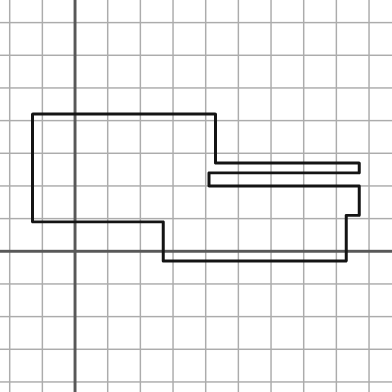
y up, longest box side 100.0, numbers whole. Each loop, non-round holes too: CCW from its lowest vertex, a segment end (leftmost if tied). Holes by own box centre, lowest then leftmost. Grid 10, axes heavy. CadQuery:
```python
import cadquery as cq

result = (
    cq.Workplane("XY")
    .moveTo(27.0, -3.0)
    .lineTo(83.0, -3.0)
    .lineTo(83.0, 11.0)
    .lineTo(87.0, 11.0)
    .lineTo(87.0, 20.0)
    .lineTo(41.0, 20.0)
    .lineTo(41.0, 24.0)
    .lineTo(87.0, 24.0)
    .lineTo(87.0, 27.0)
    .lineTo(43.0, 27.0)
    .lineTo(43.0, 42.0)
    .lineTo(-13.0, 42.0)
    .lineTo(-13.0, 9.0)
    .lineTo(27.0, 9.0)
    .close()
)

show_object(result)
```